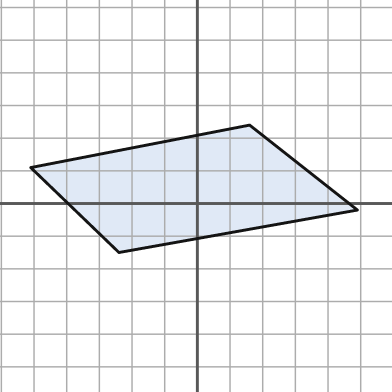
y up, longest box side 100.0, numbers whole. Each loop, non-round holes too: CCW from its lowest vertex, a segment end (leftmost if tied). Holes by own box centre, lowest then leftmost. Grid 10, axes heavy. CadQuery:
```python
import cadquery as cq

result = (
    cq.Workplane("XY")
    .moveTo(-24.0, -15.0)
    .lineTo(49.0, -2.0)
    .lineTo(16.0, 24.0)
    .lineTo(-51.0, 11.0)
    .close()
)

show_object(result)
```